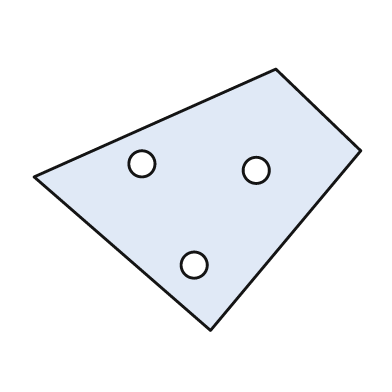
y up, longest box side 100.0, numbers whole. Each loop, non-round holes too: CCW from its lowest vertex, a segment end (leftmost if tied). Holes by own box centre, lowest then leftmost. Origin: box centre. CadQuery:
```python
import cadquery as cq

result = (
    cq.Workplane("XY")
    .moveTo(4.0, -40.0)
    .lineTo(50.0, 15.0)
    .lineTo(24.0, 40.0)
    .lineTo(-50.0, 7.0)
    .close()
    .moveTo(-1.0, -20.0)
    .circle(4.0)
    .moveTo(18.0, 9.0)
    .circle(4.0)
    .moveTo(-17.0, 11.0)
    .circle(4.0)
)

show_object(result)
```